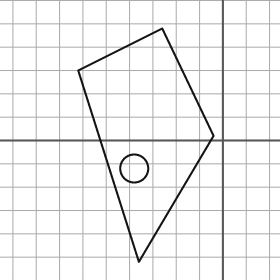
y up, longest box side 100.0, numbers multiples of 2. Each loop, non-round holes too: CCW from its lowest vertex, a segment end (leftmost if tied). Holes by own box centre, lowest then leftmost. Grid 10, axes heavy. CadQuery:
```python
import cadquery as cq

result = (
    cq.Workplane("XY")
    .moveTo(-36.0, -52.0)
    .lineTo(-4.0, 2.0)
    .lineTo(-26.0, 48.0)
    .lineTo(-62.0, 30.0)
    .close()
    .moveTo(-38.0, -12.0)
    .circle(6.0)
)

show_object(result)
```